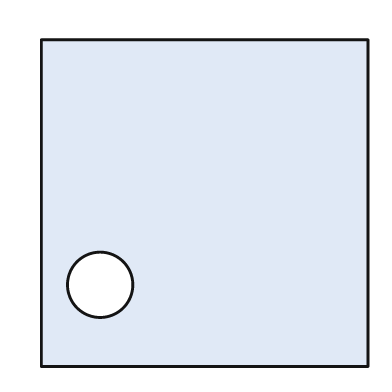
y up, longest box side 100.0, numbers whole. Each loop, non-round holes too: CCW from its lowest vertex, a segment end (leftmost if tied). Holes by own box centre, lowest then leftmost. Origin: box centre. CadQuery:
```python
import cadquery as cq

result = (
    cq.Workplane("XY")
    .moveTo(-50.0, -50.0)
    .lineTo(50.0, -50.0)
    .lineTo(50.0, 50.0)
    .lineTo(-50.0, 50.0)
    .close()
    .moveTo(-32.0, -25.0)
    .circle(10.0)
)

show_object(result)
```